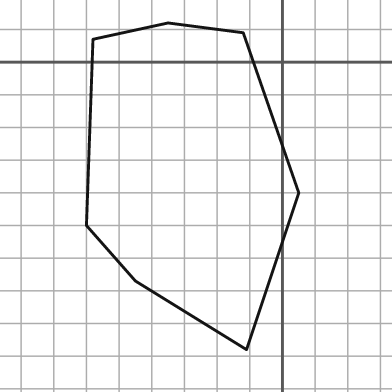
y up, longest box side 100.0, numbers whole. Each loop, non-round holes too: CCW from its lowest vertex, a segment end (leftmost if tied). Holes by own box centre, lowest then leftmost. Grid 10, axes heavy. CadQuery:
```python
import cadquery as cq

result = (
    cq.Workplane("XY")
    .moveTo(-11.0, -88.0)
    .lineTo(5.0, -40.0)
    .lineTo(-12.0, 9.0)
    .lineTo(-35.0, 12.0)
    .lineTo(-58.0, 7.0)
    .lineTo(-60.0, -50.0)
    .lineTo(-45.0, -67.0)
    .close()
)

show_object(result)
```